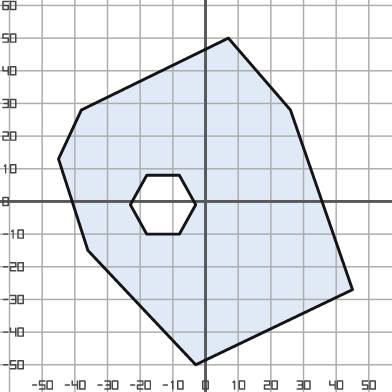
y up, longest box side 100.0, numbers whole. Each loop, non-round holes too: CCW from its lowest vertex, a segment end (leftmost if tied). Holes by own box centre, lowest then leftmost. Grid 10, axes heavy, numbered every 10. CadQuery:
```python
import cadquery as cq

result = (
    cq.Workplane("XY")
    .moveTo(-3.0, -50.0)
    .lineTo(45.0, -27.0)
    .lineTo(26.0, 28.0)
    .lineTo(7.0, 50.0)
    .lineTo(-38.0, 28.0)
    .lineTo(-45.0, 13.0)
    .lineTo(-36.0, -15.0)
    .close()
    .moveTo(-18.0, -10.0)
    .lineTo(-8.0, -10.0)
    .lineTo(-3.0, -1.0)
    .lineTo(-8.0, 8.0)
    .lineTo(-18.0, 8.0)
    .lineTo(-23.0, -1.0)
    .close()
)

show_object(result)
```